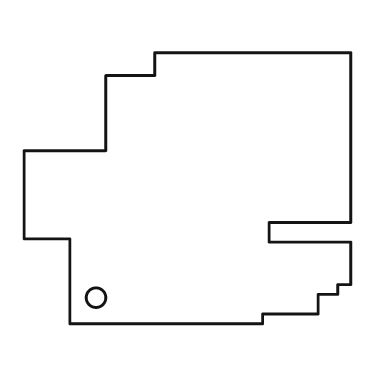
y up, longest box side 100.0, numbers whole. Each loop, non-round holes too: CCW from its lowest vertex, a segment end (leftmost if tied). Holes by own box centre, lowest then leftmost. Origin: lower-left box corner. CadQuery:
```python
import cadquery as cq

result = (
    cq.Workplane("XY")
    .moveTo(14.0, 0.0)
    .lineTo(73.0, 0.0)
    .lineTo(73.0, 3.0)
    .lineTo(90.0, 3.0)
    .lineTo(90.0, 9.0)
    .lineTo(96.0, 9.0)
    .lineTo(96.0, 12.0)
    .lineTo(100.0, 12.0)
    .lineTo(100.0, 25.0)
    .lineTo(75.0, 25.0)
    .lineTo(75.0, 31.0)
    .lineTo(100.0, 31.0)
    .lineTo(100.0, 83.0)
    .lineTo(40.0, 83.0)
    .lineTo(40.0, 76.0)
    .lineTo(25.0, 76.0)
    .lineTo(25.0, 53.0)
    .lineTo(0.0, 53.0)
    .lineTo(0.0, 26.0)
    .lineTo(14.0, 26.0)
    .close()
    .moveTo(22.0, 8.0)
    .circle(3.0)
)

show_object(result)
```